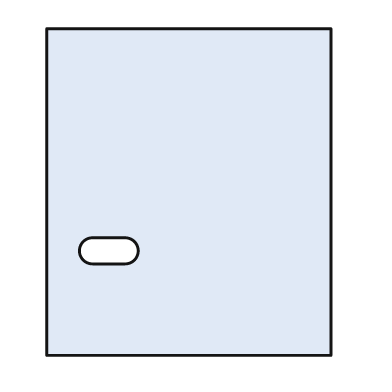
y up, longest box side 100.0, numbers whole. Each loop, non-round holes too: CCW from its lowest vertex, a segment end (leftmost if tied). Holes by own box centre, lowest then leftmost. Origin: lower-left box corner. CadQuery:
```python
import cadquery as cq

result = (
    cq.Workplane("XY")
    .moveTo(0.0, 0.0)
    .lineTo(87.0, 0.0)
    .lineTo(87.0, 100.0)
    .lineTo(0.0, 100.0)
    .close()
    .moveTo(14.0, 28.0)
    .lineTo(24.0, 28.0)
    .threePointArc((28.0, 32.0), (24.0, 36.0))
    .lineTo(14.0, 36.0)
    .threePointArc((10.0, 32.0), (14.0, 28.0))
    .close()
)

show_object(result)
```